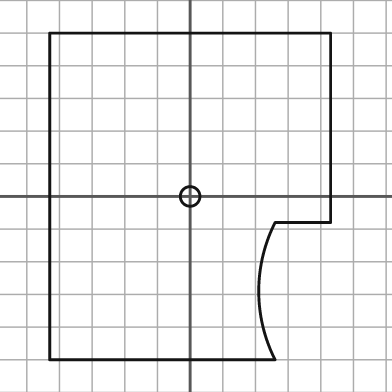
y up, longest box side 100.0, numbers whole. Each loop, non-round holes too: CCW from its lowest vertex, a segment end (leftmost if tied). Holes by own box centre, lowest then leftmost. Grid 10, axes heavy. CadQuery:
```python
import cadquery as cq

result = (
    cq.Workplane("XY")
    .moveTo(-43.0, -50.0)
    .lineTo(26.0, -50.0)
    .threePointArc((21.0, -29.0), (26.0, -8.0))
    .lineTo(43.0, -8.0)
    .lineTo(43.0, 50.0)
    .lineTo(-43.0, 50.0)
    .close()
    .moveTo(0.0, 0.0)
    .circle(3.0)
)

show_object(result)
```